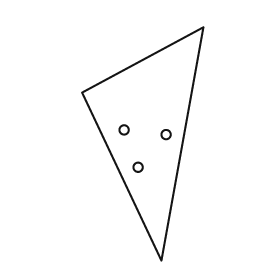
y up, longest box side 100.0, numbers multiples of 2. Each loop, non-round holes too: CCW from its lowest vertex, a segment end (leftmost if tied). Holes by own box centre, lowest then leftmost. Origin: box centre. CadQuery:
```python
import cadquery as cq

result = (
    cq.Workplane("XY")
    .moveTo(8.0, -50.0)
    .lineTo(26.0, 50.0)
    .lineTo(-26.0, 22.0)
    .close()
    .moveTo(-2.0, -10.0)
    .circle(2.0)
    .moveTo(10.0, 4.0)
    .circle(2.0)
    .moveTo(-8.0, 6.0)
    .circle(2.0)
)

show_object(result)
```